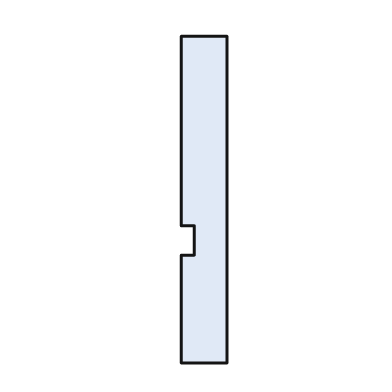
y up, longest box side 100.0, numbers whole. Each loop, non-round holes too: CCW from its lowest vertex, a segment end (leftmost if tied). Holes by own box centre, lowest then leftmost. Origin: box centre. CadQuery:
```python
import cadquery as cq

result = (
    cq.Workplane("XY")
    .moveTo(-7.0, -50.0)
    .lineTo(7.0, -50.0)
    .lineTo(7.0, 50.0)
    .lineTo(-7.0, 50.0)
    .lineTo(-7.0, -8.0)
    .lineTo(-3.0, -8.0)
    .lineTo(-3.0, -17.0)
    .lineTo(-7.0, -17.0)
    .close()
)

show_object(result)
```